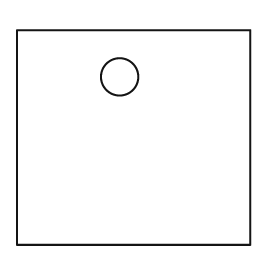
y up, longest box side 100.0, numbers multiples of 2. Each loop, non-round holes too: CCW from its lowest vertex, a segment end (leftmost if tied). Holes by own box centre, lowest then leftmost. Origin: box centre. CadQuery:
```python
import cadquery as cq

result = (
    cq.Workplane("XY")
    .moveTo(-50.0, -46.0)
    .lineTo(50.0, -46.0)
    .lineTo(50.0, 46.0)
    .lineTo(-50.0, 46.0)
    .close()
    .moveTo(-6.0, 26.0)
    .circle(8.0)
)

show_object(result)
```